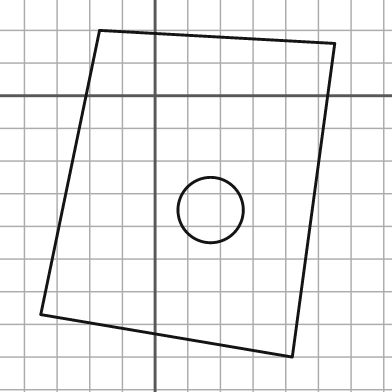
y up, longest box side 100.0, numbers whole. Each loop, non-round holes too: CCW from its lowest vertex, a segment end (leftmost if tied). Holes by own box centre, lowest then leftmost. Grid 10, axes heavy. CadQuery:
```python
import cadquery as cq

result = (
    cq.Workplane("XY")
    .moveTo(42.0, -80.0)
    .lineTo(55.0, 16.0)
    .lineTo(-17.0, 20.0)
    .lineTo(-35.0, -67.0)
    .close()
    .moveTo(17.0, -35.0)
    .circle(10.0)
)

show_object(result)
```